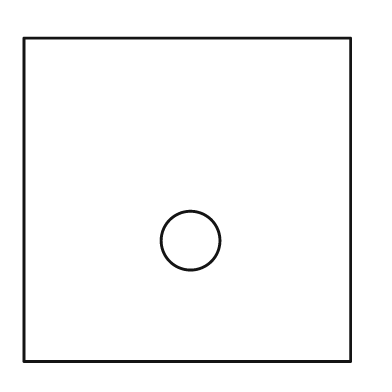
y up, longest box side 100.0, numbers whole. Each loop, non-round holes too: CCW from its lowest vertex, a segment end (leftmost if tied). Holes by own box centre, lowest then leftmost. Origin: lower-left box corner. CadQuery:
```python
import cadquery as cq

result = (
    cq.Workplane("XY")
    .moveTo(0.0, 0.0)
    .lineTo(100.0, 0.0)
    .lineTo(100.0, 99.0)
    .lineTo(0.0, 99.0)
    .close()
    .moveTo(51.0, 37.0)
    .circle(9.0)
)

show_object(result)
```